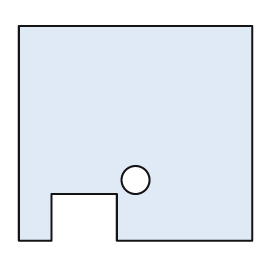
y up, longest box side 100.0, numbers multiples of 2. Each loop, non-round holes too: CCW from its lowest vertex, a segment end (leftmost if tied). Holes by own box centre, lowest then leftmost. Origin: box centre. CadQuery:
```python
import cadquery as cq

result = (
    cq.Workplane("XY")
    .moveTo(-50.0, -46.0)
    .lineTo(-36.0, -46.0)
    .lineTo(-36.0, -26.0)
    .lineTo(-8.0, -26.0)
    .lineTo(-8.0, -46.0)
    .lineTo(50.0, -46.0)
    .lineTo(50.0, 46.0)
    .lineTo(-50.0, 46.0)
    .close()
    .moveTo(0.0, -20.0)
    .circle(6.0)
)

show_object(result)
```